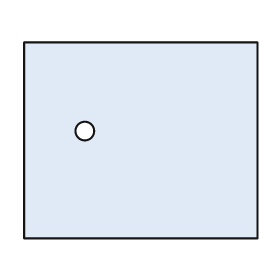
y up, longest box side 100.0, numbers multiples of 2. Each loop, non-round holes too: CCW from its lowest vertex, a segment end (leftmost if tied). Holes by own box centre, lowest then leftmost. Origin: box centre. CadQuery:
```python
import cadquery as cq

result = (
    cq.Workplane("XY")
    .moveTo(-50.0, -42.0)
    .lineTo(50.0, -42.0)
    .lineTo(50.0, 42.0)
    .lineTo(-50.0, 42.0)
    .close()
    .moveTo(-24.0, 4.0)
    .circle(4.0)
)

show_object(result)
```